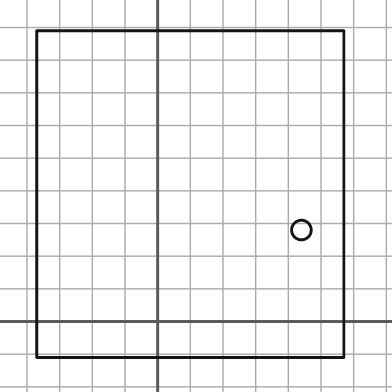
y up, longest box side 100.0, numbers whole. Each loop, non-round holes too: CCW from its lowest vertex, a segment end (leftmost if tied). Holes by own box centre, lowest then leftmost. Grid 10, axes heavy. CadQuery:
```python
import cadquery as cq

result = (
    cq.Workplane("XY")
    .moveTo(-37.0, -11.0)
    .lineTo(57.0, -11.0)
    .lineTo(57.0, 89.0)
    .lineTo(-37.0, 89.0)
    .close()
    .moveTo(44.0, 28.0)
    .circle(3.0)
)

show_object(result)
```